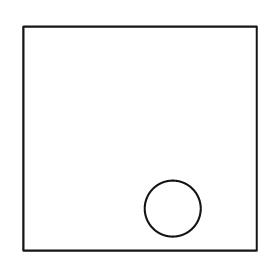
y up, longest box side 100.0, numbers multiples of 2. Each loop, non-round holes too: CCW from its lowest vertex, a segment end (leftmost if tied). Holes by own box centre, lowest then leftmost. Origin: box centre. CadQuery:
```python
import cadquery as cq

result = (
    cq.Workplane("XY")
    .moveTo(-50.0, -48.0)
    .lineTo(50.0, -48.0)
    .lineTo(50.0, 48.0)
    .lineTo(-50.0, 48.0)
    .close()
    .moveTo(14.0, -30.0)
    .circle(12.0)
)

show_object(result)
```